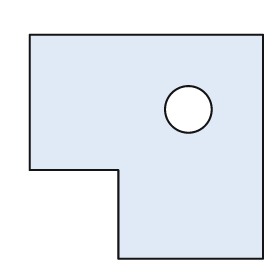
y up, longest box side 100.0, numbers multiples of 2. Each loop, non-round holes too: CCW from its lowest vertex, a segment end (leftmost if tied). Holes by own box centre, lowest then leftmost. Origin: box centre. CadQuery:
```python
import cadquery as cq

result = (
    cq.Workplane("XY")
    .moveTo(-12.0, -48.0)
    .lineTo(50.0, -48.0)
    .lineTo(50.0, 48.0)
    .lineTo(-50.0, 48.0)
    .lineTo(-50.0, -10.0)
    .lineTo(-12.0, -10.0)
    .close()
    .moveTo(18.0, 16.0)
    .circle(10.0)
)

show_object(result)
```